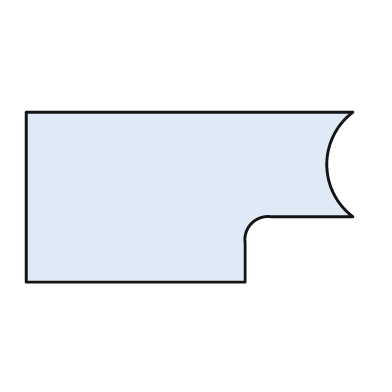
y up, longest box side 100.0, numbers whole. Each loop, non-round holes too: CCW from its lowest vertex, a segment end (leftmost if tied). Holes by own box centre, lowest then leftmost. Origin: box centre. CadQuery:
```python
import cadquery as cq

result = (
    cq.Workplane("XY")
    .moveTo(-50.0, -26.0)
    .lineTo(17.0, -26.0)
    .lineTo(17.0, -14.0)
    .threePointArc((19.0, -8.0), (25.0, -6.0))
    .lineTo(50.0, -6.0)
    .threePointArc((42.0, 10.0), (50.0, 26.0))
    .lineTo(-50.0, 26.0)
    .close()
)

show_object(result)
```